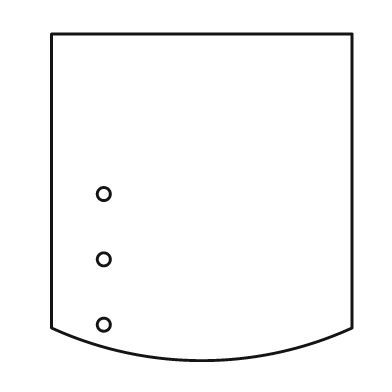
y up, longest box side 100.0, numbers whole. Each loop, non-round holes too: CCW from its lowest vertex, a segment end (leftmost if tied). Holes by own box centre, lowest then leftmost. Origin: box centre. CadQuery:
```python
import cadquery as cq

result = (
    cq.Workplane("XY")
    .moveTo(-46.0, -40.0)
    .threePointArc((0.0, -50.0), (46.0, -40.0))
    .lineTo(46.0, 50.0)
    .lineTo(-46.0, 50.0)
    .close()
    .moveTo(-30.0, -39.0)
    .circle(2.0)
    .moveTo(-30.0, -19.0)
    .circle(2.0)
    .moveTo(-30.0, 1.0)
    .circle(2.0)
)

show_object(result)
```